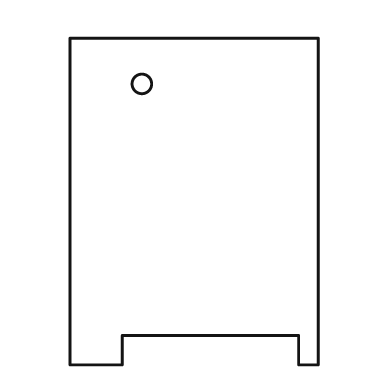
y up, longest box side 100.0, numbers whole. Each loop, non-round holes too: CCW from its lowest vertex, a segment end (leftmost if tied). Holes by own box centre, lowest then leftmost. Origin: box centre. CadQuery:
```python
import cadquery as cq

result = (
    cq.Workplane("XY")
    .moveTo(-38.0, -50.0)
    .lineTo(-22.0, -50.0)
    .lineTo(-22.0, -41.0)
    .lineTo(32.0, -41.0)
    .lineTo(32.0, -50.0)
    .lineTo(38.0, -50.0)
    .lineTo(38.0, 50.0)
    .lineTo(-38.0, 50.0)
    .close()
    .moveTo(-16.0, 36.0)
    .circle(3.0)
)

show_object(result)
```